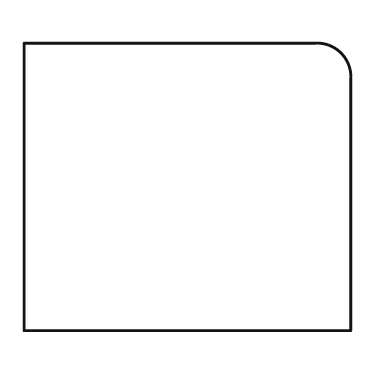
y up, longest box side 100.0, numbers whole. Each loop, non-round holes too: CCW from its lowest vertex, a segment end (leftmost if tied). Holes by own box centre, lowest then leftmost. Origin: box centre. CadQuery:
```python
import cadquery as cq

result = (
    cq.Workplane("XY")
    .moveTo(-50.0, -44.0)
    .lineTo(50.0, -44.0)
    .lineTo(50.0, 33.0)
    .threePointArc((47.0, 41.0), (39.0, 44.0))
    .lineTo(-50.0, 44.0)
    .close()
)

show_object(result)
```